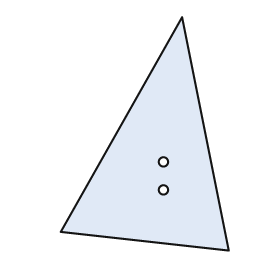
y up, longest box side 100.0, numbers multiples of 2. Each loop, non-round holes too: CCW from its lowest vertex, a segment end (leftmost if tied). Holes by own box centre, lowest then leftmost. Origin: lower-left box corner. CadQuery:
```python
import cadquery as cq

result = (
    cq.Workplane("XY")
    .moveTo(72.0, 0.0)
    .lineTo(52.0, 100.0)
    .lineTo(0.0, 8.0)
    .close()
    .moveTo(44.0, 26.0)
    .circle(2.0)
    .moveTo(44.0, 38.0)
    .circle(2.0)
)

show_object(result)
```